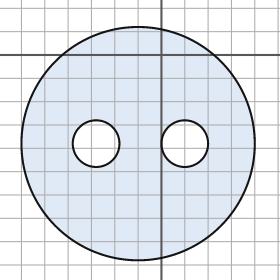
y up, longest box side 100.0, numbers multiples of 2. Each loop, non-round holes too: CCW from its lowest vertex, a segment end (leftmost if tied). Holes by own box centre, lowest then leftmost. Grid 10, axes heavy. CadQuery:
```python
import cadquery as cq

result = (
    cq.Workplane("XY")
    .moveTo(-10.0, -38.0)
    .circle(50.0)
    .moveTo(-28.0, -38.0)
    .circle(10.0)
    .moveTo(10.0, -38.0)
    .circle(10.0)
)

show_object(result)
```